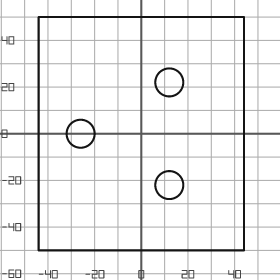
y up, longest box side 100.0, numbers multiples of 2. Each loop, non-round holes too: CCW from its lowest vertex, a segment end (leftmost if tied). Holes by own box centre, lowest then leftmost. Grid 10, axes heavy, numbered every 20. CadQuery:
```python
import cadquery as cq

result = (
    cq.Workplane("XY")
    .moveTo(-44.0, -50.0)
    .lineTo(44.0, -50.0)
    .lineTo(44.0, 50.0)
    .lineTo(-44.0, 50.0)
    .close()
    .moveTo(12.0, -22.0)
    .circle(6.0)
    .moveTo(-26.0, 0.0)
    .circle(6.0)
    .moveTo(12.0, 22.0)
    .circle(6.0)
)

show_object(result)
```